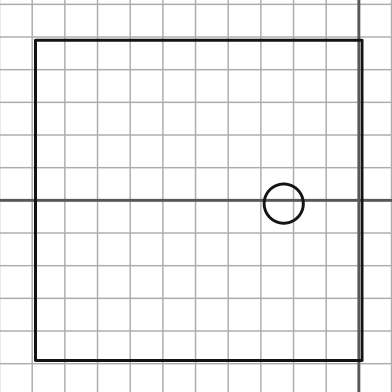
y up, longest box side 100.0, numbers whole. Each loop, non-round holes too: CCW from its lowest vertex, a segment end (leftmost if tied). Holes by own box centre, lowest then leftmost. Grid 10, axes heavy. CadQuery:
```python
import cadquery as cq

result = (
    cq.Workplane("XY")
    .moveTo(-99.0, -49.0)
    .lineTo(1.0, -49.0)
    .lineTo(1.0, 49.0)
    .lineTo(-99.0, 49.0)
    .close()
    .moveTo(-23.0, -1.0)
    .circle(6.0)
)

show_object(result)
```